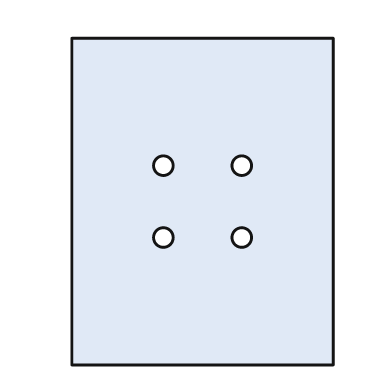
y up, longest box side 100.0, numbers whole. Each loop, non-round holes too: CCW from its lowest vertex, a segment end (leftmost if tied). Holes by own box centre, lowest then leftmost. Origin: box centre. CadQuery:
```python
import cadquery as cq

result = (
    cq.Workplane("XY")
    .moveTo(-40.0, -50.0)
    .lineTo(40.0, -50.0)
    .lineTo(40.0, 50.0)
    .lineTo(-40.0, 50.0)
    .close()
    .moveTo(-12.0, -11.0)
    .circle(3.0)
    .moveTo(12.0, -11.0)
    .circle(3.0)
    .moveTo(-12.0, 11.0)
    .circle(3.0)
    .moveTo(12.0, 11.0)
    .circle(3.0)
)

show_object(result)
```